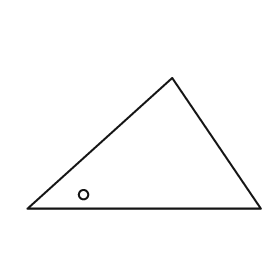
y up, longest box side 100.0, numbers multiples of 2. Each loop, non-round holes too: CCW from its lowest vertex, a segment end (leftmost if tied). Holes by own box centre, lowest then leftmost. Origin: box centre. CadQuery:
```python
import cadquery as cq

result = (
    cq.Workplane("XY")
    .moveTo(-50.0, -28.0)
    .lineTo(50.0, -28.0)
    .lineTo(12.0, 28.0)
    .close()
    .moveTo(-26.0, -22.0)
    .circle(2.0)
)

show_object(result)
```